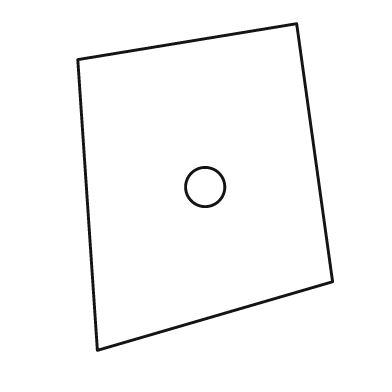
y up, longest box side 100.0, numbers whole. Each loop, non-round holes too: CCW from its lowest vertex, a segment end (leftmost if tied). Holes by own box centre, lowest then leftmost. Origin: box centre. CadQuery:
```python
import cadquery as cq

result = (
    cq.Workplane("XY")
    .moveTo(-33.0, -50.0)
    .lineTo(39.0, -29.0)
    .lineTo(28.0, 50.0)
    .lineTo(-39.0, 39.0)
    .close()
    .moveTo(0.0, 0.0)
    .circle(6.0)
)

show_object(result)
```